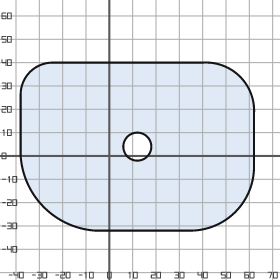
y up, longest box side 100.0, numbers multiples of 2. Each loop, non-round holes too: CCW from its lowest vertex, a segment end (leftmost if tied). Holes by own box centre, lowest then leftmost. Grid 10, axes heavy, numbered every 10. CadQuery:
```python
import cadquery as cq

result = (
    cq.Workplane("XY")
    .moveTo(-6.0, -32.0)
    .lineTo(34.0, -32.0)
    .threePointArc((54.0, -24.0), (62.0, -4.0))
    .lineTo(62.0, 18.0)
    .threePointArc((56.0, 34.0), (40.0, 40.0))
    .lineTo(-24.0, 40.0)
    .threePointArc((-34.0, 36.0), (-38.0, 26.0))
    .lineTo(-38.0, 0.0)
    .threePointArc((-28.0, -22.0), (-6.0, -32.0))
    .close()
    .moveTo(12.0, 4.0)
    .circle(6.0)
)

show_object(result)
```